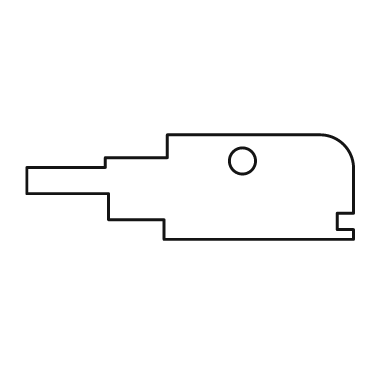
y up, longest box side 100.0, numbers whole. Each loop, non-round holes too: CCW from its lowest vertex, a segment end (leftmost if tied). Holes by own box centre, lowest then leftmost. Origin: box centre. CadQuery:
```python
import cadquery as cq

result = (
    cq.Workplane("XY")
    .moveTo(-8.0, -16.0)
    .lineTo(50.0, -16.0)
    .lineTo(50.0, -13.0)
    .lineTo(45.0, -13.0)
    .lineTo(45.0, -8.0)
    .lineTo(50.0, -8.0)
    .lineTo(50.0, 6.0)
    .threePointArc((47.0, 13.0), (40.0, 16.0))
    .lineTo(-7.0, 16.0)
    .lineTo(-7.0, 9.0)
    .lineTo(-26.0, 9.0)
    .lineTo(-26.0, 6.0)
    .lineTo(-50.0, 6.0)
    .lineTo(-50.0, -2.0)
    .lineTo(-25.0, -2.0)
    .lineTo(-25.0, -10.0)
    .lineTo(-8.0, -10.0)
    .close()
    .moveTo(16.0, 8.0)
    .circle(4.0)
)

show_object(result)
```